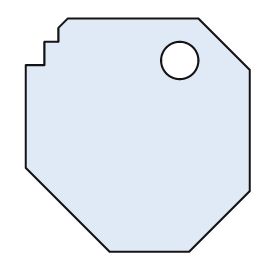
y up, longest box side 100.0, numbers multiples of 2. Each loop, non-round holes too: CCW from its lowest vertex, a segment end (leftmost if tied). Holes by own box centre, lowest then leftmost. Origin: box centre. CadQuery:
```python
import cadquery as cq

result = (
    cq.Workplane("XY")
    .moveTo(-12.0, -50.0)
    .lineTo(22.0, -50.0)
    .lineTo(48.0, -24.0)
    .lineTo(48.0, 28.0)
    .lineTo(26.0, 50.0)
    .lineTo(-30.0, 50.0)
    .lineTo(-34.0, 46.0)
    .lineTo(-34.0, 40.0)
    .lineTo(-40.0, 40.0)
    .lineTo(-40.0, 30.0)
    .lineTo(-48.0, 30.0)
    .lineTo(-48.0, -14.0)
    .close()
    .moveTo(18.0, 32.0)
    .circle(8.0)
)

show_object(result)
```